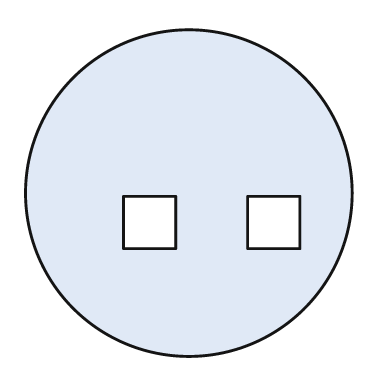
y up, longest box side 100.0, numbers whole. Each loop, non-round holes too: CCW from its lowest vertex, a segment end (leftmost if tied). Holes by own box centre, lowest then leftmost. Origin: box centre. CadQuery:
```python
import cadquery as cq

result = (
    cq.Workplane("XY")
    .moveTo(0.0, 0.0)
    .circle(50.0)
    .moveTo(-20.0, -17.0)
    .lineTo(-4.0, -17.0)
    .lineTo(-4.0, -1.0)
    .lineTo(-20.0, -1.0)
    .close()
    .moveTo(18.0, -17.0)
    .lineTo(34.0, -17.0)
    .lineTo(34.0, -1.0)
    .lineTo(18.0, -1.0)
    .close()
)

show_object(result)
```